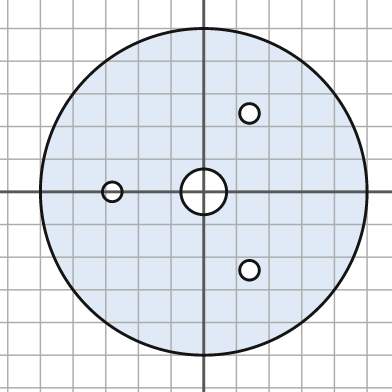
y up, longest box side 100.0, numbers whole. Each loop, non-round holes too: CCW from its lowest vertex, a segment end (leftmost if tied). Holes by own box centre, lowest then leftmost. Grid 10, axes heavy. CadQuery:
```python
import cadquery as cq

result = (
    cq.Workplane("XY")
    .moveTo(0.0, 0.0)
    .circle(50.0)
    .moveTo(14.0, -24.0)
    .circle(3.0)
    .moveTo(-28.0, 0.0)
    .circle(3.0)
    .moveTo(0.0, 0.0)
    .circle(7.0)
    .moveTo(14.0, 24.0)
    .circle(3.0)
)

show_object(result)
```